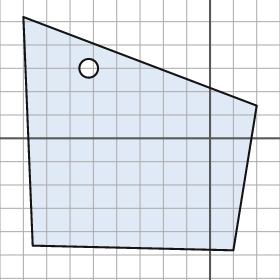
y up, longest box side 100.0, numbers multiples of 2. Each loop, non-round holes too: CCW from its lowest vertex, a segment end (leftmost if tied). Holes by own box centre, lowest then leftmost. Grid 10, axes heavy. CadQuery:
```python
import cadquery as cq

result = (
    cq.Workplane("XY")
    .moveTo(10.0, -48.0)
    .lineTo(20.0, 14.0)
    .lineTo(-80.0, 52.0)
    .lineTo(-76.0, -46.0)
    .close()
    .moveTo(-52.0, 30.0)
    .circle(4.0)
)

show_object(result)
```